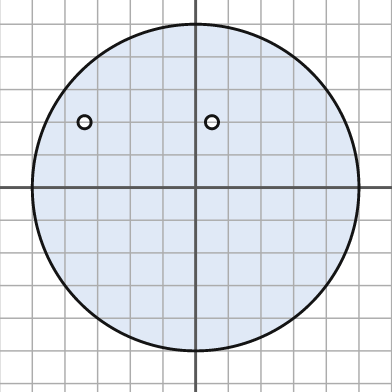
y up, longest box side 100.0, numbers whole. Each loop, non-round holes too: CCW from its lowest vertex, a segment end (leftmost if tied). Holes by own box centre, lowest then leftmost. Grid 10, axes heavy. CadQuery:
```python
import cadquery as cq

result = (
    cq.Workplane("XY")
    .moveTo(0.0, 0.0)
    .circle(50.0)
    .moveTo(-34.0, 20.0)
    .circle(2.0)
    .moveTo(5.0, 20.0)
    .circle(2.0)
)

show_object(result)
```